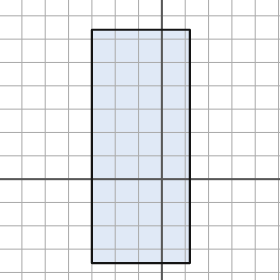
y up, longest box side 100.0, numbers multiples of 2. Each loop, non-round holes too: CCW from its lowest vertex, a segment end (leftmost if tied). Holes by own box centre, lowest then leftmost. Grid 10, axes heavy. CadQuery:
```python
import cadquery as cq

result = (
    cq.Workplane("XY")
    .moveTo(-30.0, -36.0)
    .lineTo(12.0, -36.0)
    .lineTo(12.0, 64.0)
    .lineTo(-30.0, 64.0)
    .close()
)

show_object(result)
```